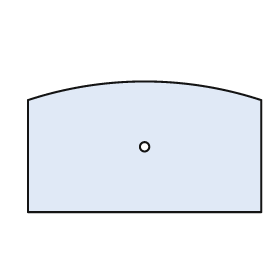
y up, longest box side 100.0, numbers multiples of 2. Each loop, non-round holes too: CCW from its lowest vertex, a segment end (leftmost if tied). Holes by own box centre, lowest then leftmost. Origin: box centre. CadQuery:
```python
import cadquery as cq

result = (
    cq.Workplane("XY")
    .moveTo(-50.0, -28.0)
    .lineTo(50.0, -28.0)
    .lineTo(50.0, 20.0)
    .threePointArc((0.0, 28.0), (-50.0, 20.0))
    .close()
    .moveTo(0.0, 0.0)
    .circle(2.0)
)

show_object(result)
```